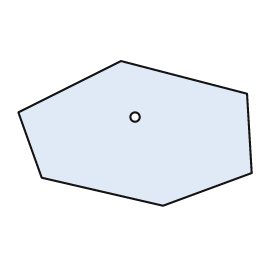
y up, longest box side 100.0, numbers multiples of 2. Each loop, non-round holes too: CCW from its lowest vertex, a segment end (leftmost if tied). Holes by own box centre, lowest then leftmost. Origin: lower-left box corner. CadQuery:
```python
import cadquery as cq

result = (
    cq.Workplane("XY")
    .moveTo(62.0, 0.0)
    .lineTo(100.0, 14.0)
    .lineTo(98.0, 48.0)
    .lineTo(44.0, 62.0)
    .lineTo(0.0, 40.0)
    .lineTo(10.0, 12.0)
    .close()
    .moveTo(50.0, 38.0)
    .circle(2.0)
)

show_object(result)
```